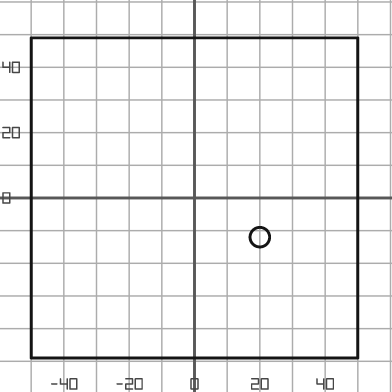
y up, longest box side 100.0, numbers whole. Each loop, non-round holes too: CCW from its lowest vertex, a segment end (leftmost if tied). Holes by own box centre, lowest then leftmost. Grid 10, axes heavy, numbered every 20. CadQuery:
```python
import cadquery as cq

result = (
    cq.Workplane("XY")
    .moveTo(-50.0, -49.0)
    .lineTo(50.0, -49.0)
    .lineTo(50.0, 49.0)
    .lineTo(-50.0, 49.0)
    .close()
    .moveTo(20.0, -12.0)
    .circle(3.0)
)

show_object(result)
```